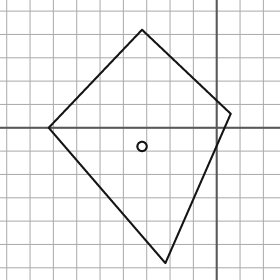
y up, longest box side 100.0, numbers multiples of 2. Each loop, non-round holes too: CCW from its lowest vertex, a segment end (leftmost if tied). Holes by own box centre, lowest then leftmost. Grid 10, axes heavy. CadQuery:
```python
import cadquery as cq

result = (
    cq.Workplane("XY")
    .moveTo(-22.0, -58.0)
    .lineTo(6.0, 6.0)
    .lineTo(-32.0, 42.0)
    .lineTo(-72.0, 0.0)
    .close()
    .moveTo(-32.0, -8.0)
    .circle(2.0)
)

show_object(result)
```